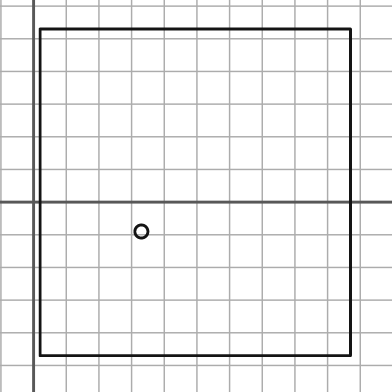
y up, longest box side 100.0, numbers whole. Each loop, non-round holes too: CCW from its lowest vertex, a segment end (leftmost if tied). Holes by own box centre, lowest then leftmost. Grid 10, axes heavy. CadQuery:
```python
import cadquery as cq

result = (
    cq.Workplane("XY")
    .moveTo(2.0, -47.0)
    .lineTo(97.0, -47.0)
    .lineTo(97.0, 53.0)
    .lineTo(2.0, 53.0)
    .close()
    .moveTo(33.0, -9.0)
    .circle(2.0)
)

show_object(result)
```